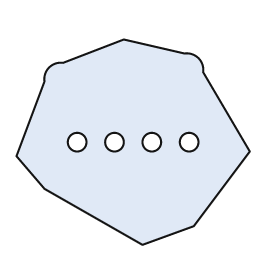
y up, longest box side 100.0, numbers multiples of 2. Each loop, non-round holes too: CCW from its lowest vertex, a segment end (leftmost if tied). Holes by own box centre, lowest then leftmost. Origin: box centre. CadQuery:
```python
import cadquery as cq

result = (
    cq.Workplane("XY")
    .moveTo(4.0, -44.0)
    .lineTo(26.0, -36.0)
    .lineTo(50.0, -4.0)
    .lineTo(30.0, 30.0)
    .threePointArc((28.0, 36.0), (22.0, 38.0))
    .lineTo(-4.0, 44.0)
    .lineTo(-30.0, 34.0)
    .threePointArc((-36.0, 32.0), (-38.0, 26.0))
    .lineTo(-50.0, -6.0)
    .lineTo(-38.0, -20.0)
    .close()
    .moveTo(-24.0, 0.0)
    .circle(4.0)
    .moveTo(-8.0, 0.0)
    .circle(4.0)
    .moveTo(8.0, 0.0)
    .circle(4.0)
    .moveTo(24.0, 0.0)
    .circle(4.0)
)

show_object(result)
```